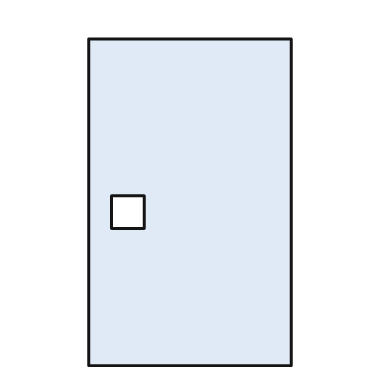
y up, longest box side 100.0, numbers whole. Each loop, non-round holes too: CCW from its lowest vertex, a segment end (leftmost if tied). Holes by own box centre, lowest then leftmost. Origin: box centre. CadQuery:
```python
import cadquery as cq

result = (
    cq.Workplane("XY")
    .moveTo(-31.0, -50.0)
    .lineTo(31.0, -50.0)
    .lineTo(31.0, 50.0)
    .lineTo(-31.0, 50.0)
    .close()
    .moveTo(-24.0, -8.0)
    .lineTo(-14.0, -8.0)
    .lineTo(-14.0, 2.0)
    .lineTo(-24.0, 2.0)
    .close()
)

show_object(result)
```